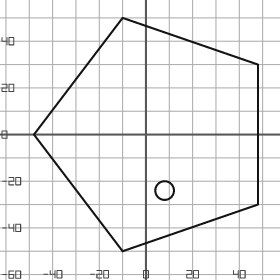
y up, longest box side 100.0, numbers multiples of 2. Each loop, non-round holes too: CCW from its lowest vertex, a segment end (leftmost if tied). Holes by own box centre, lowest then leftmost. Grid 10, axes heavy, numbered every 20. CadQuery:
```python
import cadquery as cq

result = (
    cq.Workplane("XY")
    .moveTo(-10.0, -50.0)
    .lineTo(48.0, -30.0)
    .lineTo(48.0, 30.0)
    .lineTo(-10.0, 50.0)
    .lineTo(-48.0, 0.0)
    .close()
    .moveTo(8.0, -24.0)
    .circle(4.0)
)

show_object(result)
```